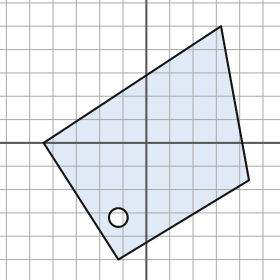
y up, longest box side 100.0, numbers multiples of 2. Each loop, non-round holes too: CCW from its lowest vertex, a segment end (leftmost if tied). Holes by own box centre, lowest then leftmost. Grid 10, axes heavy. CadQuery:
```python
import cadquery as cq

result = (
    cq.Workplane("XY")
    .moveTo(-12.0, -50.0)
    .lineTo(44.0, -16.0)
    .lineTo(32.0, 50.0)
    .lineTo(-44.0, 0.0)
    .close()
    .moveTo(-12.0, -32.0)
    .circle(4.0)
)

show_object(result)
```